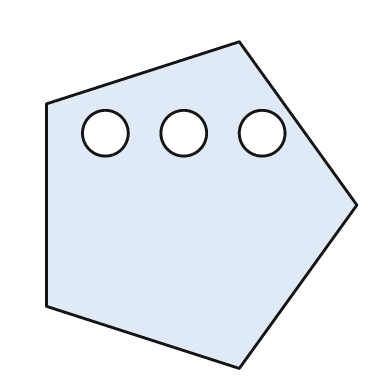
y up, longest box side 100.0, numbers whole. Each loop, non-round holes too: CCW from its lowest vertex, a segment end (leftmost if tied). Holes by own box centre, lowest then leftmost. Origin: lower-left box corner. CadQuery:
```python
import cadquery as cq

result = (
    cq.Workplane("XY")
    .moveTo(59.0, 0.0)
    .lineTo(95.0, 50.0)
    .lineTo(59.0, 100.0)
    .lineTo(0.0, 81.0)
    .lineTo(0.0, 19.0)
    .close()
    .moveTo(18.0, 72.0)
    .circle(7.0)
    .moveTo(42.0, 72.0)
    .circle(7.0)
    .moveTo(66.0, 72.0)
    .circle(7.0)
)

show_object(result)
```